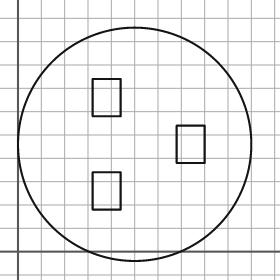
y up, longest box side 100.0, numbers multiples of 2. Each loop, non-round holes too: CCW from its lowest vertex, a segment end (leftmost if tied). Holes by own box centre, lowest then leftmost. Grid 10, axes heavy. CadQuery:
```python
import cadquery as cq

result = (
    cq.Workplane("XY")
    .moveTo(50.0, 46.0)
    .circle(50.0)
    .moveTo(32.0, 18.0)
    .lineTo(44.0, 18.0)
    .lineTo(44.0, 34.0)
    .lineTo(32.0, 34.0)
    .close()
    .moveTo(68.0, 38.0)
    .lineTo(80.0, 38.0)
    .lineTo(80.0, 54.0)
    .lineTo(68.0, 54.0)
    .close()
    .moveTo(32.0, 58.0)
    .lineTo(44.0, 58.0)
    .lineTo(44.0, 74.0)
    .lineTo(32.0, 74.0)
    .close()
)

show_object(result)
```